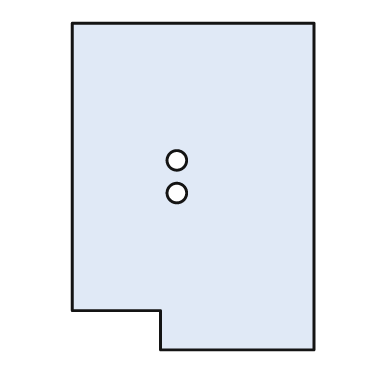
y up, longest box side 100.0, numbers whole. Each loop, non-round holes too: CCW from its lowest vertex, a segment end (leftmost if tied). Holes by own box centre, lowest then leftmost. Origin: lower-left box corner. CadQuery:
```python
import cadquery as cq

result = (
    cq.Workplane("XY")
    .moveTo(27.0, 0.0)
    .lineTo(74.0, 0.0)
    .lineTo(74.0, 100.0)
    .lineTo(0.0, 100.0)
    .lineTo(0.0, 12.0)
    .lineTo(27.0, 12.0)
    .close()
    .moveTo(32.0, 48.0)
    .circle(3.0)
    .moveTo(32.0, 58.0)
    .circle(3.0)
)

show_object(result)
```